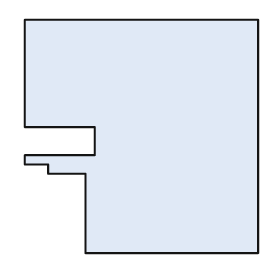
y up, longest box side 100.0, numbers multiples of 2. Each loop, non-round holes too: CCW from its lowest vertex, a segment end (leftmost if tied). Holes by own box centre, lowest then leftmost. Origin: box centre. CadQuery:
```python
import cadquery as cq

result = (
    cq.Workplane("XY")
    .moveTo(-24.0, -50.0)
    .lineTo(50.0, -50.0)
    .lineTo(50.0, 50.0)
    .lineTo(-50.0, 50.0)
    .lineTo(-50.0, 4.0)
    .lineTo(-20.0, 4.0)
    .lineTo(-20.0, -8.0)
    .lineTo(-50.0, -8.0)
    .lineTo(-50.0, -12.0)
    .lineTo(-40.0, -12.0)
    .lineTo(-40.0, -16.0)
    .lineTo(-24.0, -16.0)
    .close()
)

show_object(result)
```